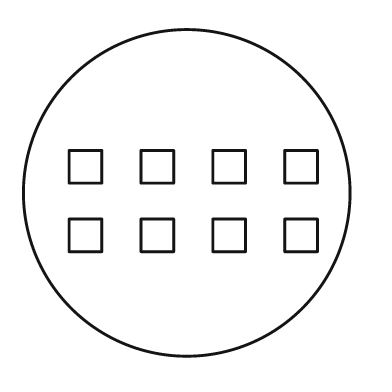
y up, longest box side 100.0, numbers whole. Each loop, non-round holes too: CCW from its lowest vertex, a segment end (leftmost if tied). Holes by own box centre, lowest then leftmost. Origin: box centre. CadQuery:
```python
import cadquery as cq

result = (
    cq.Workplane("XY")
    .moveTo(0.0, 0.0)
    .circle(50.0)
    .moveTo(-36.0, -18.0)
    .lineTo(-26.0, -18.0)
    .lineTo(-26.0, -8.0)
    .lineTo(-36.0, -8.0)
    .close()
    .moveTo(-14.0, -18.0)
    .lineTo(-4.0, -18.0)
    .lineTo(-4.0, -8.0)
    .lineTo(-14.0, -8.0)
    .close()
    .moveTo(8.0, -18.0)
    .lineTo(18.0, -18.0)
    .lineTo(18.0, -8.0)
    .lineTo(8.0, -8.0)
    .close()
    .moveTo(30.0, -18.0)
    .lineTo(40.0, -18.0)
    .lineTo(40.0, -8.0)
    .lineTo(30.0, -8.0)
    .close()
    .moveTo(-36.0, 3.0)
    .lineTo(-26.0, 3.0)
    .lineTo(-26.0, 13.0)
    .lineTo(-36.0, 13.0)
    .close()
    .moveTo(-14.0, 3.0)
    .lineTo(-4.0, 3.0)
    .lineTo(-4.0, 13.0)
    .lineTo(-14.0, 13.0)
    .close()
    .moveTo(8.0, 3.0)
    .lineTo(18.0, 3.0)
    .lineTo(18.0, 13.0)
    .lineTo(8.0, 13.0)
    .close()
    .moveTo(30.0, 3.0)
    .lineTo(40.0, 3.0)
    .lineTo(40.0, 13.0)
    .lineTo(30.0, 13.0)
    .close()
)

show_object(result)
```